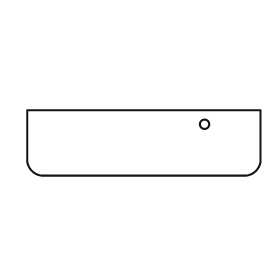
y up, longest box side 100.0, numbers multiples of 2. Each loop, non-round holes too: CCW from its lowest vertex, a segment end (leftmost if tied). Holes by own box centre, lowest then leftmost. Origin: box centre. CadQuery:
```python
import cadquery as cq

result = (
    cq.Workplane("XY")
    .moveTo(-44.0, -14.0)
    .lineTo(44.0, -14.0)
    .threePointArc((48.0, -12.0), (50.0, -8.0))
    .lineTo(50.0, 14.0)
    .lineTo(-50.0, 14.0)
    .lineTo(-50.0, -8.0)
    .threePointArc((-48.0, -12.0), (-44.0, -14.0))
    .close()
    .moveTo(26.0, 8.0)
    .circle(2.0)
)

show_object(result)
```